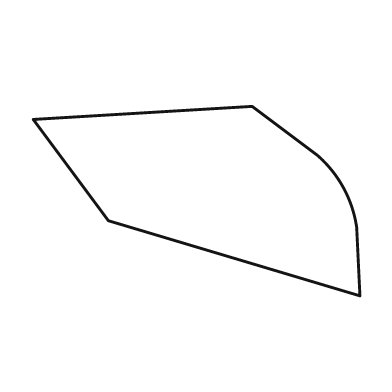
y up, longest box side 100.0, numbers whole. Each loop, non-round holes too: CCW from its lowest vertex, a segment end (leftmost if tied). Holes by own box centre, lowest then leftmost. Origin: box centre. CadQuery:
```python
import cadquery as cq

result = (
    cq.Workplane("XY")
    .moveTo(50.0, -29.0)
    .lineTo(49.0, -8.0)
    .threePointArc((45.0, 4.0), (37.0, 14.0))
    .lineTo(17.0, 29.0)
    .lineTo(-50.0, 25.0)
    .lineTo(-27.0, -6.0)
    .close()
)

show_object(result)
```